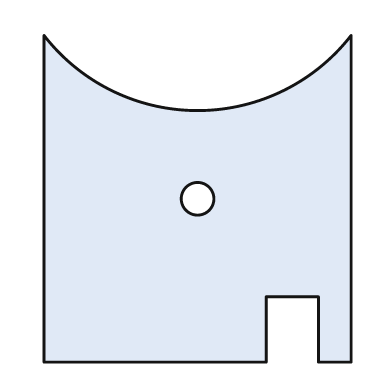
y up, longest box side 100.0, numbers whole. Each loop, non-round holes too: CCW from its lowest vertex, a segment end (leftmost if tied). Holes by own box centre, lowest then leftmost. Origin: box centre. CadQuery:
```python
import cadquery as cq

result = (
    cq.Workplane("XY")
    .moveTo(-47.0, -50.0)
    .lineTo(21.0, -50.0)
    .lineTo(21.0, -30.0)
    .lineTo(37.0, -30.0)
    .lineTo(37.0, -50.0)
    .lineTo(47.0, -50.0)
    .lineTo(47.0, 50.0)
    .threePointArc((0.0, 27.0), (-47.0, 50.0))
    .close()
    .moveTo(0.0, 0.0)
    .circle(5.0)
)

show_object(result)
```